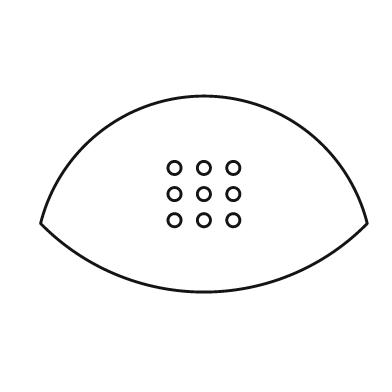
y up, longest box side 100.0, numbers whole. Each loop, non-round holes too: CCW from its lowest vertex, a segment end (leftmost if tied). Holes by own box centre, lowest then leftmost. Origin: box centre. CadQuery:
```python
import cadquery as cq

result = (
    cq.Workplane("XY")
    .moveTo(-50.0, -9.0)
    .threePointArc((0.0, -30.0), (50.0, -9.0))
    .threePointArc((0.0, 30.0), (-50.0, -9.0))
    .close()
    .moveTo(-9.0, -8.0)
    .circle(2.0)
    .moveTo(0.0, -8.0)
    .circle(2.0)
    .moveTo(9.0, -8.0)
    .circle(2.0)
    .moveTo(-9.0, 0.0)
    .circle(2.0)
    .moveTo(0.0, 0.0)
    .circle(2.0)
    .moveTo(9.0, 0.0)
    .circle(2.0)
    .moveTo(-9.0, 8.0)
    .circle(2.0)
    .moveTo(0.0, 8.0)
    .circle(2.0)
    .moveTo(9.0, 8.0)
    .circle(2.0)
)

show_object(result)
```